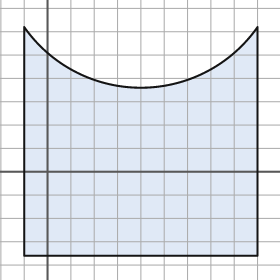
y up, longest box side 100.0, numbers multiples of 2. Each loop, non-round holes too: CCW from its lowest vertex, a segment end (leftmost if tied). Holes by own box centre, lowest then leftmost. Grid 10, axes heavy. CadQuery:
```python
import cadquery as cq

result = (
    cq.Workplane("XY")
    .moveTo(-10.0, -36.0)
    .lineTo(90.0, -36.0)
    .lineTo(90.0, 62.0)
    .threePointArc((40.0, 36.0), (-10.0, 62.0))
    .close()
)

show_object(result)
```